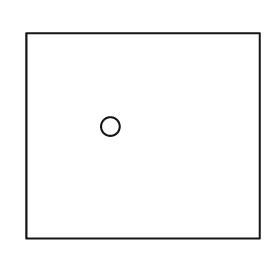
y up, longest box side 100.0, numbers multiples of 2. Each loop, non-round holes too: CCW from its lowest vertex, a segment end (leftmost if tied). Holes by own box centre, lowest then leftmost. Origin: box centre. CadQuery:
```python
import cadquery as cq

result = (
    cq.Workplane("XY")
    .moveTo(-50.0, -44.0)
    .lineTo(50.0, -44.0)
    .lineTo(50.0, 44.0)
    .lineTo(-50.0, 44.0)
    .close()
    .moveTo(-14.0, 4.0)
    .circle(4.0)
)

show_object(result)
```